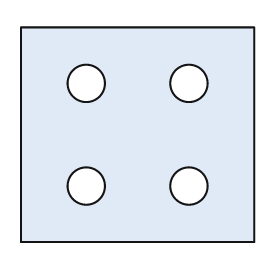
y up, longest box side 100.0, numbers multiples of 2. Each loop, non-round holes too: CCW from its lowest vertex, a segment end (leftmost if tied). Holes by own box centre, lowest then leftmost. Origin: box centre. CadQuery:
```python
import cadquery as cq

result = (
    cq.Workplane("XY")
    .moveTo(-50.0, -46.0)
    .lineTo(50.0, -46.0)
    .lineTo(50.0, 46.0)
    .lineTo(-50.0, 46.0)
    .close()
    .moveTo(-22.0, -22.0)
    .circle(8.0)
    .moveTo(22.0, -22.0)
    .circle(8.0)
    .moveTo(-22.0, 22.0)
    .circle(8.0)
    .moveTo(22.0, 22.0)
    .circle(8.0)
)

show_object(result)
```